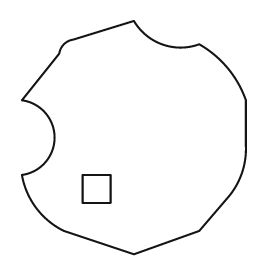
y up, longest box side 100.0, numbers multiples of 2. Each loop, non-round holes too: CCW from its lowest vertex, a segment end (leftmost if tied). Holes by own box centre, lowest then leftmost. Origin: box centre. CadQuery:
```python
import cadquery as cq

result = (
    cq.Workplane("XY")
    .moveTo(0.0, -50.0)
    .lineTo(28.0, -40.0)
    .lineTo(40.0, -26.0)
    .threePointArc((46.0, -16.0), (48.0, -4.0))
    .lineTo(48.0, 16.0)
    .threePointArc((40.0, 30.0), (28.0, 40.0))
    .threePointArc((12.0, 40.0), (0.0, 50.0))
    .lineTo(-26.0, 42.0)
    .threePointArc((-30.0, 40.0), (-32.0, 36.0))
    .lineTo(-48.0, 16.0)
    .threePointArc((-34.0, 0.0), (-48.0, -16.0))
    .threePointArc((-42.0, -30.0), (-30.0, -40.0))
    .close()
    .moveTo(-22.0, -28.0)
    .lineTo(-10.0, -28.0)
    .lineTo(-10.0, -16.0)
    .lineTo(-22.0, -16.0)
    .close()
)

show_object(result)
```